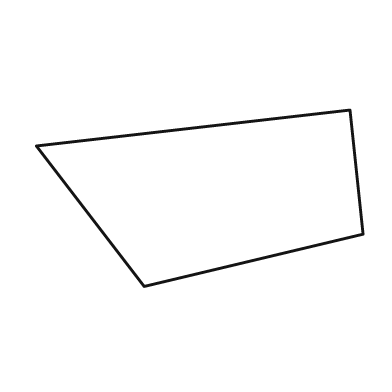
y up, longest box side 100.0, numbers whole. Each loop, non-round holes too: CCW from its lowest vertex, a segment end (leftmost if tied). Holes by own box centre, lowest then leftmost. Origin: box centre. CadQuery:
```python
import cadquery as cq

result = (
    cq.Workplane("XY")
    .moveTo(-17.0, -27.0)
    .lineTo(50.0, -11.0)
    .lineTo(46.0, 27.0)
    .lineTo(-50.0, 16.0)
    .close()
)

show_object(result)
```